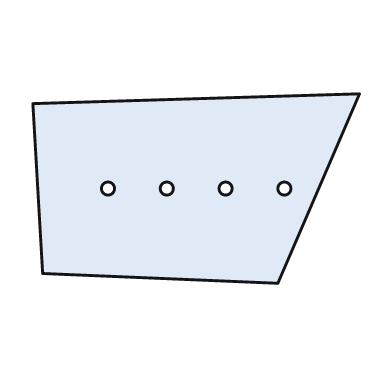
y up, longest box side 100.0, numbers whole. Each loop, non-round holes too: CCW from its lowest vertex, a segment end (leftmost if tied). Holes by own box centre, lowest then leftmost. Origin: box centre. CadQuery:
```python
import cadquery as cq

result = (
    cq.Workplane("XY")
    .moveTo(25.0, -29.0)
    .lineTo(50.0, 29.0)
    .lineTo(-50.0, 26.0)
    .lineTo(-47.0, -26.0)
    .close()
    .moveTo(-27.0, 0.0)
    .circle(2.0)
    .moveTo(-9.0, 0.0)
    .circle(2.0)
    .moveTo(9.0, 0.0)
    .circle(2.0)
    .moveTo(27.0, 0.0)
    .circle(2.0)
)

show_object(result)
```